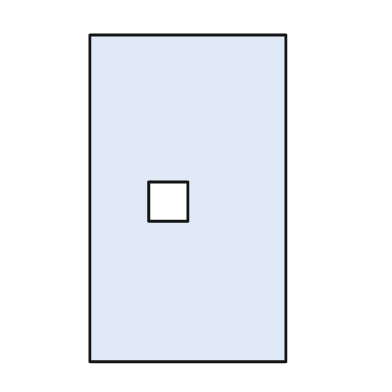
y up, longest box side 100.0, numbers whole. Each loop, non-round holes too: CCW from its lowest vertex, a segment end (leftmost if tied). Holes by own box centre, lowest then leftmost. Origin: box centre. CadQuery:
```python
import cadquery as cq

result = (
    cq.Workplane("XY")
    .moveTo(-30.0, -50.0)
    .lineTo(30.0, -50.0)
    .lineTo(30.0, 50.0)
    .lineTo(-30.0, 50.0)
    .close()
    .moveTo(-12.0, -7.0)
    .lineTo(0.0, -7.0)
    .lineTo(0.0, 5.0)
    .lineTo(-12.0, 5.0)
    .close()
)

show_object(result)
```